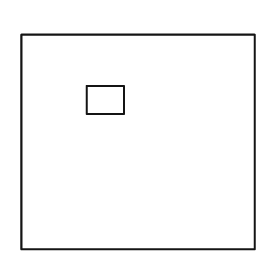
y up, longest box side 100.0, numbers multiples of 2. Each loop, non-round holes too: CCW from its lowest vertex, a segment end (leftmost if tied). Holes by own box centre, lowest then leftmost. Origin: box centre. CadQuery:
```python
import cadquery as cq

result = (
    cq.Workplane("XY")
    .moveTo(-50.0, -46.0)
    .lineTo(50.0, -46.0)
    .lineTo(50.0, 46.0)
    .lineTo(-50.0, 46.0)
    .close()
    .moveTo(-22.0, 12.0)
    .lineTo(-6.0, 12.0)
    .lineTo(-6.0, 24.0)
    .lineTo(-22.0, 24.0)
    .close()
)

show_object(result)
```